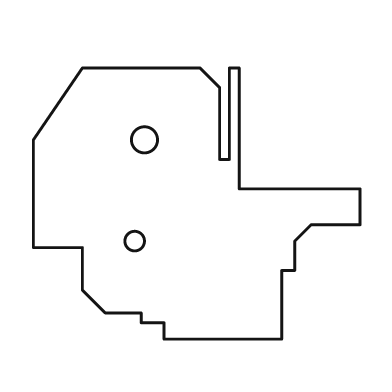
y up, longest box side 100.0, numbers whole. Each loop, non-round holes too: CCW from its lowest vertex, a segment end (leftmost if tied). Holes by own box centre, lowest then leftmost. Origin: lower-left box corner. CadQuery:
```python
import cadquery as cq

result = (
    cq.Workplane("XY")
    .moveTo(40.0, 0.0)
    .lineTo(76.0, 0.0)
    .lineTo(76.0, 21.0)
    .lineTo(80.0, 21.0)
    .lineTo(80.0, 30.0)
    .lineTo(85.0, 35.0)
    .lineTo(100.0, 35.0)
    .lineTo(100.0, 46.0)
    .lineTo(63.0, 46.0)
    .lineTo(63.0, 83.0)
    .lineTo(60.0, 83.0)
    .lineTo(60.0, 55.0)
    .lineTo(57.0, 55.0)
    .lineTo(57.0, 77.0)
    .lineTo(51.0, 83.0)
    .lineTo(15.0, 83.0)
    .lineTo(0.0, 61.0)
    .lineTo(0.0, 28.0)
    .lineTo(15.0, 28.0)
    .lineTo(15.0, 15.0)
    .lineTo(22.0, 8.0)
    .lineTo(33.0, 8.0)
    .lineTo(33.0, 5.0)
    .lineTo(40.0, 5.0)
    .close()
    .moveTo(31.0, 30.0)
    .circle(3.0)
    .moveTo(34.0, 61.0)
    .circle(4.0)
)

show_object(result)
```